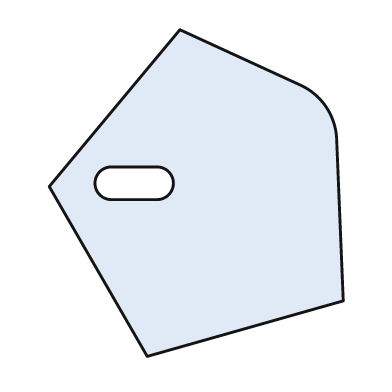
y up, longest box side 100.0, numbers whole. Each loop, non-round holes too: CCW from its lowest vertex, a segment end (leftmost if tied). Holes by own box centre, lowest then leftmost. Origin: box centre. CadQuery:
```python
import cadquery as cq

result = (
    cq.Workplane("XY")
    .moveTo(-15.0, -50.0)
    .lineTo(45.0, -33.0)
    .lineTo(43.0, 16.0)
    .threePointArc((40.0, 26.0), (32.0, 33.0))
    .lineTo(-5.0, 50.0)
    .lineTo(-45.0, 2.0)
    .close()
    .moveTo(-26.0, -2.0)
    .lineTo(-12.0, -2.0)
    .threePointArc((-7.0, 3.0), (-12.0, 8.0))
    .lineTo(-26.0, 8.0)
    .threePointArc((-31.0, 3.0), (-26.0, -2.0))
    .close()
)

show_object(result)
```